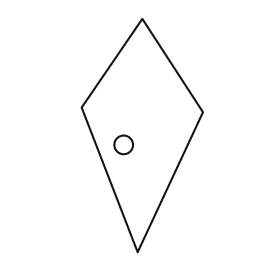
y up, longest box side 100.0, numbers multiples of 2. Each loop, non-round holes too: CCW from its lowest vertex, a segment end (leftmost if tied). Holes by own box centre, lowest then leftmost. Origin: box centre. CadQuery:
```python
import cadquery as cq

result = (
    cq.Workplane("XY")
    .moveTo(-2.0, -50.0)
    .lineTo(26.0, 10.0)
    .lineTo(0.0, 50.0)
    .lineTo(-26.0, 12.0)
    .close()
    .moveTo(-8.0, -4.0)
    .circle(4.0)
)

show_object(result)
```